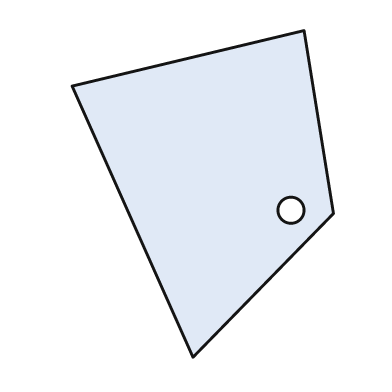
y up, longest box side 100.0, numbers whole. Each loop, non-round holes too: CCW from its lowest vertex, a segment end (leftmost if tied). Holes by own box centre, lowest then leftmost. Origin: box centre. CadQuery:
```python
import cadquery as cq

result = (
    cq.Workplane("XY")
    .moveTo(-3.0, -50.0)
    .lineTo(40.0, -6.0)
    .lineTo(31.0, 50.0)
    .lineTo(-40.0, 33.0)
    .close()
    .moveTo(27.0, -5.0)
    .circle(4.0)
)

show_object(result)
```